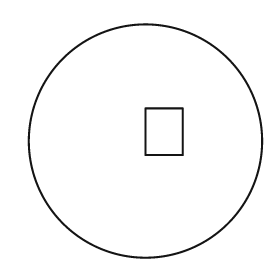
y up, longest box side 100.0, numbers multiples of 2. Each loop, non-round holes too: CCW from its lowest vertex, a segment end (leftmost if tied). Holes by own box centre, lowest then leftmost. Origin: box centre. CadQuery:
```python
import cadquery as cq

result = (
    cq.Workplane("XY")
    .moveTo(0.0, 0.0)
    .circle(50.0)
    .moveTo(0.0, -6.0)
    .lineTo(16.0, -6.0)
    .lineTo(16.0, 14.0)
    .lineTo(0.0, 14.0)
    .close()
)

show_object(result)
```